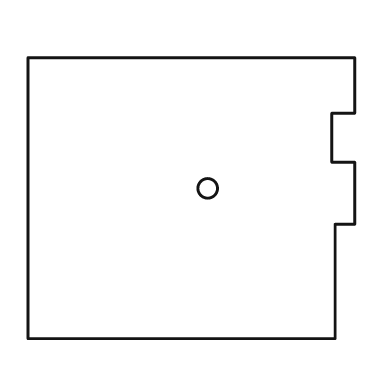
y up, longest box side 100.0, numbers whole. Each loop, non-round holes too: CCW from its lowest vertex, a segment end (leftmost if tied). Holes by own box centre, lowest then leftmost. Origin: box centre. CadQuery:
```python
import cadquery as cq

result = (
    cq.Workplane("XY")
    .moveTo(-50.0, -43.0)
    .lineTo(44.0, -43.0)
    .lineTo(44.0, -8.0)
    .lineTo(50.0, -8.0)
    .lineTo(50.0, 11.0)
    .lineTo(43.0, 11.0)
    .lineTo(43.0, 26.0)
    .lineTo(50.0, 26.0)
    .lineTo(50.0, 43.0)
    .lineTo(-50.0, 43.0)
    .close()
    .moveTo(5.0, 3.0)
    .circle(3.0)
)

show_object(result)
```